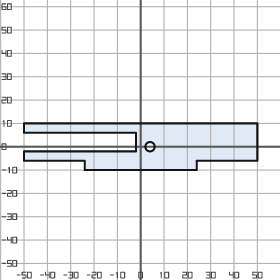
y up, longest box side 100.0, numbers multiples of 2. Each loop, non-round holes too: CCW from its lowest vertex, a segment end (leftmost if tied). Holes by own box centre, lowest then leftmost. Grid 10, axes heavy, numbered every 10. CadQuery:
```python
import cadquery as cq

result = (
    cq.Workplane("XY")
    .moveTo(-24.0, -10.0)
    .lineTo(24.0, -10.0)
    .lineTo(24.0, -6.0)
    .lineTo(50.0, -6.0)
    .lineTo(50.0, 10.0)
    .lineTo(-50.0, 10.0)
    .lineTo(-50.0, 6.0)
    .lineTo(-2.0, 6.0)
    .lineTo(-2.0, -2.0)
    .lineTo(-50.0, -2.0)
    .lineTo(-50.0, -6.0)
    .lineTo(-24.0, -6.0)
    .close()
    .moveTo(4.0, 0.0)
    .circle(2.0)
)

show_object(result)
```